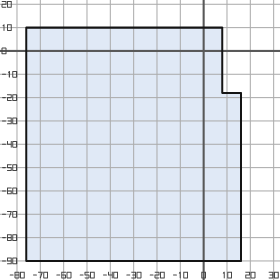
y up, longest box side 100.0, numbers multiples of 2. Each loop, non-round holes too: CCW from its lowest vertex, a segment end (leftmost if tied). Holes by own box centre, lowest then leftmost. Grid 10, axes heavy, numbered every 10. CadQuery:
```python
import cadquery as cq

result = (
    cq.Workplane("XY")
    .moveTo(-76.0, -90.0)
    .lineTo(16.0, -90.0)
    .lineTo(16.0, -18.0)
    .lineTo(8.0, -18.0)
    .lineTo(8.0, 10.0)
    .lineTo(-76.0, 10.0)
    .close()
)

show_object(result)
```